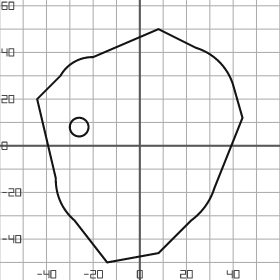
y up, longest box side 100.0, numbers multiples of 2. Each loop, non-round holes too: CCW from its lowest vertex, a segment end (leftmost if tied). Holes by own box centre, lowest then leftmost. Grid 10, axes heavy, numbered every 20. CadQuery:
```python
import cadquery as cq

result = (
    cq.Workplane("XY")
    .moveTo(-14.0, -50.0)
    .lineTo(8.0, -46.0)
    .lineTo(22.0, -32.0)
    .threePointArc((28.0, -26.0), (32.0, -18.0))
    .lineTo(44.0, 12.0)
    .lineTo(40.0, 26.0)
    .threePointArc((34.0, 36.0), (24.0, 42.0))
    .lineTo(8.0, 50.0)
    .lineTo(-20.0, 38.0)
    .threePointArc((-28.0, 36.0), (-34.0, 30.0))
    .lineTo(-44.0, 20.0)
    .lineTo(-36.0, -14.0)
    .threePointArc((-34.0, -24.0), (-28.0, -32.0))
    .close()
    .moveTo(-26.0, 8.0)
    .circle(4.0)
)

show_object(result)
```